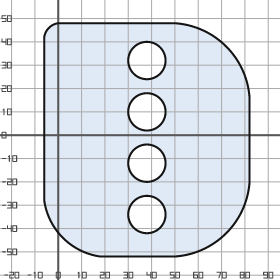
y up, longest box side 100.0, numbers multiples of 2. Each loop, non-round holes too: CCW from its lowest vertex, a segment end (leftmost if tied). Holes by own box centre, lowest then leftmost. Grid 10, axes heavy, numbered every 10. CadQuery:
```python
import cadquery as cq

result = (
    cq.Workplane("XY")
    .moveTo(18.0, -52.0)
    .lineTo(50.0, -52.0)
    .threePointArc((72.0, -42.0), (82.0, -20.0))
    .lineTo(82.0, 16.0)
    .threePointArc((72.0, 38.0), (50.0, 48.0))
    .lineTo(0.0, 48.0)
    .threePointArc((-4.0, 46.0), (-6.0, 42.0))
    .lineTo(-6.0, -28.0)
    .threePointArc((2.0, -44.0), (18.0, -52.0))
    .close()
    .moveTo(38.0, -34.0)
    .circle(8.0)
    .moveTo(38.0, -12.0)
    .circle(8.0)
    .moveTo(38.0, 10.0)
    .circle(8.0)
    .moveTo(38.0, 32.0)
    .circle(8.0)
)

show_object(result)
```